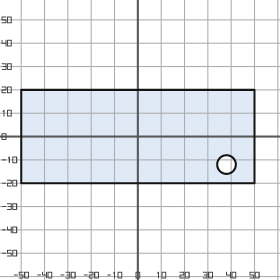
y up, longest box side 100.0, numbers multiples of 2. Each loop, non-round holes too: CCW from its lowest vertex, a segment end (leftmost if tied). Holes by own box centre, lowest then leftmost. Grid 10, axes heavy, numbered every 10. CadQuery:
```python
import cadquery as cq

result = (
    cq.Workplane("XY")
    .moveTo(-50.0, -20.0)
    .lineTo(50.0, -20.0)
    .lineTo(50.0, 20.0)
    .lineTo(-50.0, 20.0)
    .close()
    .moveTo(38.0, -12.0)
    .circle(4.0)
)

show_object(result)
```